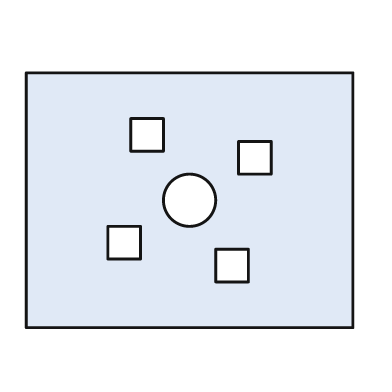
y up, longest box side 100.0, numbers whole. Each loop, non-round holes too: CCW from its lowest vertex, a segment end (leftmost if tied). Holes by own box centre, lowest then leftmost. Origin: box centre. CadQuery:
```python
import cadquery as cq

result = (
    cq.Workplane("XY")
    .moveTo(-50.0, -39.0)
    .lineTo(50.0, -39.0)
    .lineTo(50.0, 39.0)
    .lineTo(-50.0, 39.0)
    .close()
    .moveTo(8.0, -25.0)
    .lineTo(18.0, -25.0)
    .lineTo(18.0, -15.0)
    .lineTo(8.0, -15.0)
    .close()
    .moveTo(-25.0, -18.0)
    .lineTo(-15.0, -18.0)
    .lineTo(-15.0, -8.0)
    .lineTo(-25.0, -8.0)
    .close()
    .moveTo(0.0, 0.0)
    .circle(8.0)
    .moveTo(15.0, 8.0)
    .lineTo(25.0, 8.0)
    .lineTo(25.0, 18.0)
    .lineTo(15.0, 18.0)
    .close()
    .moveTo(-18.0, 15.0)
    .lineTo(-8.0, 15.0)
    .lineTo(-8.0, 25.0)
    .lineTo(-18.0, 25.0)
    .close()
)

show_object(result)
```